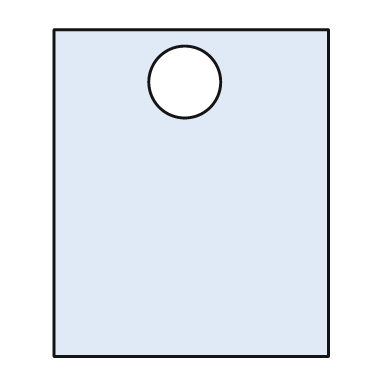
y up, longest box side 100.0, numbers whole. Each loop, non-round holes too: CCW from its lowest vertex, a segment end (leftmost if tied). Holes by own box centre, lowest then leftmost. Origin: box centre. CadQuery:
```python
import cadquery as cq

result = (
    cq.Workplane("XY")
    .moveTo(-42.0, -50.0)
    .lineTo(42.0, -50.0)
    .lineTo(42.0, 50.0)
    .lineTo(-42.0, 50.0)
    .close()
    .moveTo(-2.0, 34.0)
    .circle(11.0)
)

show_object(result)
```